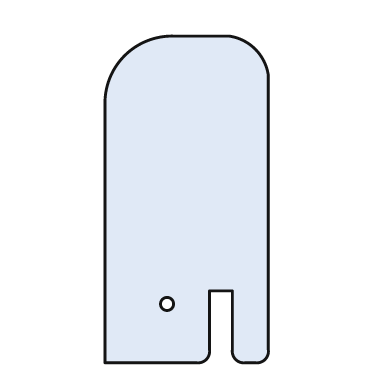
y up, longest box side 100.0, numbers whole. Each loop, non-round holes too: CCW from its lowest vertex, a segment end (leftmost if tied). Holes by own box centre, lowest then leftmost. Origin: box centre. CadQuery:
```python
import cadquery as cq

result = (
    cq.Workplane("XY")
    .moveTo(-25.0, -50.0)
    .lineTo(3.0, -50.0)
    .threePointArc((6.0, -49.0), (7.0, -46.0))
    .lineTo(7.0, -28.0)
    .lineTo(14.0, -28.0)
    .lineTo(14.0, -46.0)
    .threePointArc((15.0, -49.0), (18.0, -50.0))
    .lineTo(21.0, -50.0)
    .threePointArc((24.0, -49.0), (25.0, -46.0))
    .lineTo(25.0, 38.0)
    .threePointArc((21.0, 46.0), (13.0, 50.0))
    .lineTo(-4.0, 50.0)
    .threePointArc((-19.0, 44.0), (-25.0, 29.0))
    .close()
    .moveTo(-6.0, -32.0)
    .circle(2.0)
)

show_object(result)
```